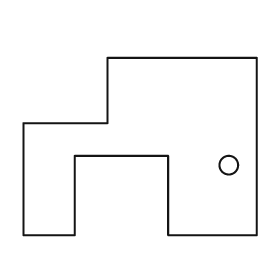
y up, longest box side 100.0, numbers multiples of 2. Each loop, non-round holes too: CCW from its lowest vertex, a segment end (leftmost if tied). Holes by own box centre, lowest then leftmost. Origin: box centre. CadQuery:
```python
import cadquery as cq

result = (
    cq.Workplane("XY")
    .moveTo(-50.0, -38.0)
    .lineTo(-28.0, -38.0)
    .lineTo(-28.0, -4.0)
    .lineTo(12.0, -4.0)
    .lineTo(12.0, -38.0)
    .lineTo(50.0, -38.0)
    .lineTo(50.0, 38.0)
    .lineTo(-14.0, 38.0)
    .lineTo(-14.0, 10.0)
    .lineTo(-50.0, 10.0)
    .close()
    .moveTo(38.0, -8.0)
    .circle(4.0)
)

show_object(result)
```